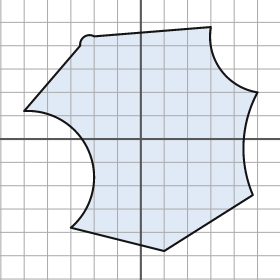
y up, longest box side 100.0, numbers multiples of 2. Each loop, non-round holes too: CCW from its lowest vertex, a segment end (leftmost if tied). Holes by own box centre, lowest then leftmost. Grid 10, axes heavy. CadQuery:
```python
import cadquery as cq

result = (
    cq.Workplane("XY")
    .moveTo(10.0, -48.0)
    .lineTo(48.0, -24.0)
    .threePointArc((44.0, -2.0), (50.0, 20.0))
    .threePointArc((34.0, 30.0), (30.0, 48.0))
    .lineTo(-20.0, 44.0)
    .threePointArc((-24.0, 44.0), (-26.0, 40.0))
    .lineTo(-50.0, 12.0)
    .threePointArc((-22.0, -6.0), (-30.0, -38.0))
    .close()
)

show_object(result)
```